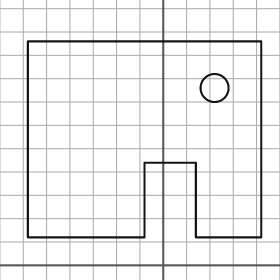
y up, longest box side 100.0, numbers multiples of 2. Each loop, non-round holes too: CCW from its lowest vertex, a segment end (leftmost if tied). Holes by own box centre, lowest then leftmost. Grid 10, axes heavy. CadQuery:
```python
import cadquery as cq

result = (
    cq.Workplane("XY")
    .moveTo(-58.0, 12.0)
    .lineTo(-8.0, 12.0)
    .lineTo(-8.0, 44.0)
    .lineTo(14.0, 44.0)
    .lineTo(14.0, 12.0)
    .lineTo(42.0, 12.0)
    .lineTo(42.0, 96.0)
    .lineTo(-58.0, 96.0)
    .close()
    .moveTo(22.0, 76.0)
    .circle(6.0)
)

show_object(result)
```